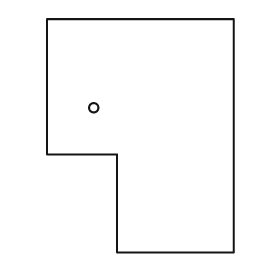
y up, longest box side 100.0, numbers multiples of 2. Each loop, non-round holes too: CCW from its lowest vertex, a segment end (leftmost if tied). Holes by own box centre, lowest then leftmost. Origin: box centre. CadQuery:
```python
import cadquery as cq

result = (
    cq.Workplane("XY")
    .moveTo(-10.0, -50.0)
    .lineTo(40.0, -50.0)
    .lineTo(40.0, 50.0)
    .lineTo(-40.0, 50.0)
    .lineTo(-40.0, -8.0)
    .lineTo(-10.0, -8.0)
    .close()
    .moveTo(-20.0, 12.0)
    .circle(2.0)
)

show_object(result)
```